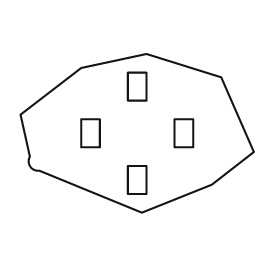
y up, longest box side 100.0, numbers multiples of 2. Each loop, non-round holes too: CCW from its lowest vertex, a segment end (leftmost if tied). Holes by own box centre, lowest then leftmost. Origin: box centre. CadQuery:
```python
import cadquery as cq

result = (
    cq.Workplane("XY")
    .moveTo(2.0, -34.0)
    .lineTo(32.0, -22.0)
    .lineTo(50.0, -8.0)
    .lineTo(36.0, 24.0)
    .lineTo(4.0, 34.0)
    .lineTo(-24.0, 28.0)
    .lineTo(-50.0, 8.0)
    .lineTo(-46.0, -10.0)
    .threePointArc((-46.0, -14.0), (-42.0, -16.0))
    .close()
    .moveTo(-4.0, -26.0)
    .lineTo(4.0, -26.0)
    .lineTo(4.0, -14.0)
    .lineTo(-4.0, -14.0)
    .close()
    .moveTo(-24.0, -6.0)
    .lineTo(-16.0, -6.0)
    .lineTo(-16.0, 6.0)
    .lineTo(-24.0, 6.0)
    .close()
    .moveTo(16.0, -6.0)
    .lineTo(24.0, -6.0)
    .lineTo(24.0, 6.0)
    .lineTo(16.0, 6.0)
    .close()
    .moveTo(-4.0, 14.0)
    .lineTo(4.0, 14.0)
    .lineTo(4.0, 26.0)
    .lineTo(-4.0, 26.0)
    .close()
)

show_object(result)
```